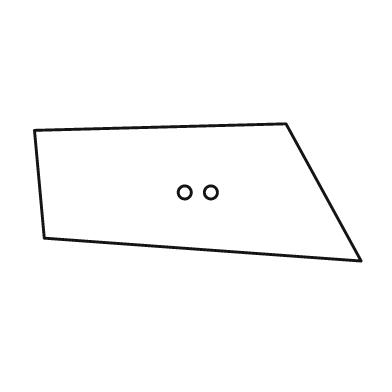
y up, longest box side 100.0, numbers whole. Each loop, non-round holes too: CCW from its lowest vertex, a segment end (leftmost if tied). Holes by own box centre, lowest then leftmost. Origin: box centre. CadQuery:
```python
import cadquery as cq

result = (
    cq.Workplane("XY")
    .moveTo(50.0, -21.0)
    .lineTo(27.0, 21.0)
    .lineTo(-50.0, 19.0)
    .lineTo(-47.0, -14.0)
    .close()
    .moveTo(-4.0, 0.0)
    .circle(2.0)
    .moveTo(4.0, 0.0)
    .circle(2.0)
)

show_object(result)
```